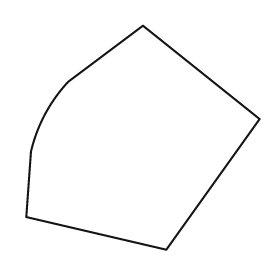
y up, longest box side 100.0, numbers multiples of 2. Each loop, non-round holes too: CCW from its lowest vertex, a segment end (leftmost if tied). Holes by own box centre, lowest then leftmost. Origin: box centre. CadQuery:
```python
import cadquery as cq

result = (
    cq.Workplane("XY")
    .moveTo(10.0, -48.0)
    .lineTo(50.0, 8.0)
    .lineTo(0.0, 48.0)
    .lineTo(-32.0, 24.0)
    .threePointArc((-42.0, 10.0), (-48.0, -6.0))
    .lineTo(-50.0, -34.0)
    .close()
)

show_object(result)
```